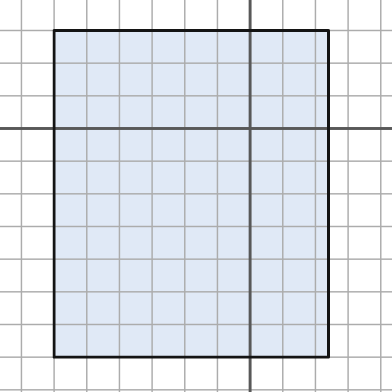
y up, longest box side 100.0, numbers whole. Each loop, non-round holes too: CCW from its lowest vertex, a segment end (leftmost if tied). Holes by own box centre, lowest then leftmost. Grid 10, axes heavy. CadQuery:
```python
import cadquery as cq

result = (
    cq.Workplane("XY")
    .moveTo(-60.0, -70.0)
    .lineTo(24.0, -70.0)
    .lineTo(24.0, 30.0)
    .lineTo(-60.0, 30.0)
    .close()
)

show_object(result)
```